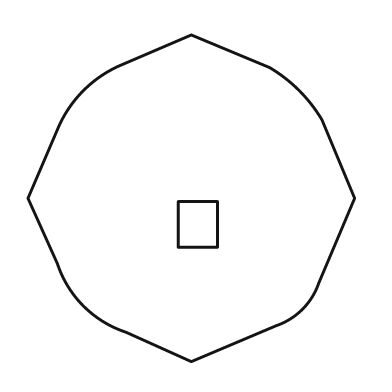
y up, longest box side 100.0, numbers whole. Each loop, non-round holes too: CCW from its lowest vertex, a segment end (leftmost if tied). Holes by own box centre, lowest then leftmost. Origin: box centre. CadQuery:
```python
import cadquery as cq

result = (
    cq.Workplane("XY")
    .moveTo(0.0, -50.0)
    .lineTo(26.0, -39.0)
    .threePointArc((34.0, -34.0), (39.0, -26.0))
    .lineTo(50.0, 0.0)
    .lineTo(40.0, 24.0)
    .threePointArc((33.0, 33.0), (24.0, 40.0))
    .lineTo(0.0, 50.0)
    .lineTo(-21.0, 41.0)
    .threePointArc((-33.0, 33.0), (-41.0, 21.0))
    .lineTo(-50.0, 0.0)
    .lineTo(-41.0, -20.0)
    .threePointArc((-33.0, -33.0), (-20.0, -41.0))
    .close()
    .moveTo(-4.0, -15.0)
    .lineTo(8.0, -15.0)
    .lineTo(8.0, -1.0)
    .lineTo(-4.0, -1.0)
    .close()
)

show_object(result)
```